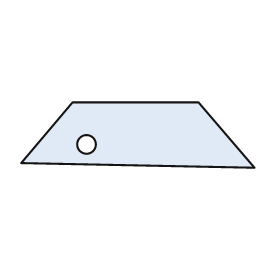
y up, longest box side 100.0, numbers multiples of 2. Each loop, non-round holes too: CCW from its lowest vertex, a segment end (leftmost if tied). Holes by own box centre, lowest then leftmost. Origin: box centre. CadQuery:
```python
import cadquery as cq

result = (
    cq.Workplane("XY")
    .moveTo(50.0, -14.0)
    .lineTo(26.0, 14.0)
    .lineTo(-28.0, 14.0)
    .lineTo(-50.0, -12.0)
    .close()
    .moveTo(-22.0, -4.0)
    .circle(4.0)
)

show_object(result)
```